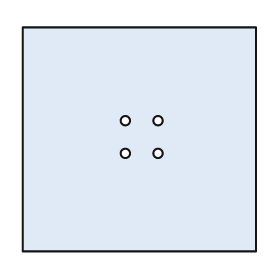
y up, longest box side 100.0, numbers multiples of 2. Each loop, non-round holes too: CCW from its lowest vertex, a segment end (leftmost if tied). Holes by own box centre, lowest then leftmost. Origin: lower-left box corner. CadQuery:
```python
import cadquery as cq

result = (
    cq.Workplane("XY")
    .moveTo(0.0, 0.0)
    .lineTo(100.0, 0.0)
    .lineTo(100.0, 96.0)
    .lineTo(0.0, 96.0)
    .close()
    .moveTo(44.0, 42.0)
    .circle(2.0)
    .moveTo(58.0, 42.0)
    .circle(2.0)
    .moveTo(44.0, 56.0)
    .circle(2.0)
    .moveTo(58.0, 56.0)
    .circle(2.0)
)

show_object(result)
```